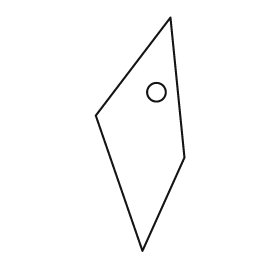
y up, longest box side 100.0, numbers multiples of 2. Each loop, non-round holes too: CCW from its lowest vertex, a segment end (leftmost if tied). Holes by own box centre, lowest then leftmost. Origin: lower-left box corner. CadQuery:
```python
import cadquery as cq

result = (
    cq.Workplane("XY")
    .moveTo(20.0, 0.0)
    .lineTo(38.0, 40.0)
    .lineTo(32.0, 100.0)
    .lineTo(0.0, 58.0)
    .close()
    .moveTo(26.0, 68.0)
    .circle(4.0)
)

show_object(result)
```